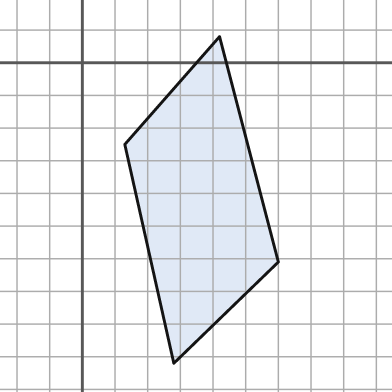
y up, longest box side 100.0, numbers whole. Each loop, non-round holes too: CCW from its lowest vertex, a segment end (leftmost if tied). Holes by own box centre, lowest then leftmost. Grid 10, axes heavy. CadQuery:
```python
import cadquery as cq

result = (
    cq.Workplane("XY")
    .moveTo(28.0, -92.0)
    .lineTo(60.0, -61.0)
    .lineTo(42.0, 8.0)
    .lineTo(13.0, -25.0)
    .close()
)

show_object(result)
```